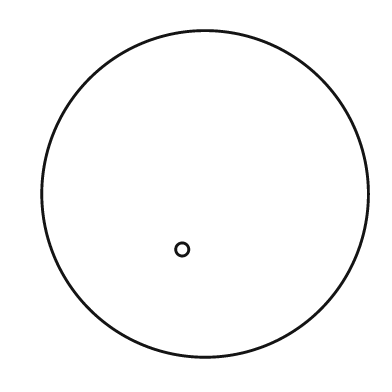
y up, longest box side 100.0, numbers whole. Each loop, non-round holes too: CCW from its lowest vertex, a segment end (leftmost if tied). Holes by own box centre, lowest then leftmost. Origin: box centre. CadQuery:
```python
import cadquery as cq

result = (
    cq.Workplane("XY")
    .moveTo(0.0, 0.0)
    .circle(50.0)
    .moveTo(-7.0, -17.0)
    .circle(2.0)
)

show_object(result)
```